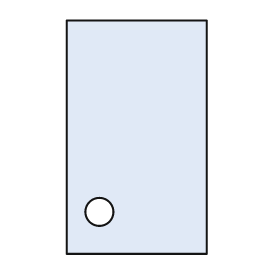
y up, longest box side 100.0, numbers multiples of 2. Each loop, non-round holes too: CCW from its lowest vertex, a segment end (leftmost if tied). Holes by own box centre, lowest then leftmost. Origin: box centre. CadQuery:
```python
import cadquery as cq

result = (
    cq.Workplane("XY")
    .moveTo(-30.0, -50.0)
    .lineTo(30.0, -50.0)
    .lineTo(30.0, 50.0)
    .lineTo(-30.0, 50.0)
    .close()
    .moveTo(-16.0, -32.0)
    .circle(6.0)
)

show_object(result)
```